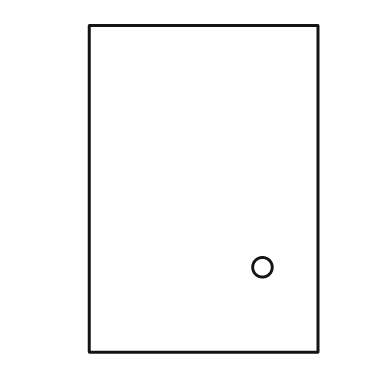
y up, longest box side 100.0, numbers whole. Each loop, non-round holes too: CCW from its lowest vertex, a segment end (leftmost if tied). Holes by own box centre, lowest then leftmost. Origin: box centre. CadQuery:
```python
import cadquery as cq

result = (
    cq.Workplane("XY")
    .moveTo(-35.0, -50.0)
    .lineTo(35.0, -50.0)
    .lineTo(35.0, 50.0)
    .lineTo(-35.0, 50.0)
    .close()
    .moveTo(18.0, -24.0)
    .circle(3.0)
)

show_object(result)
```